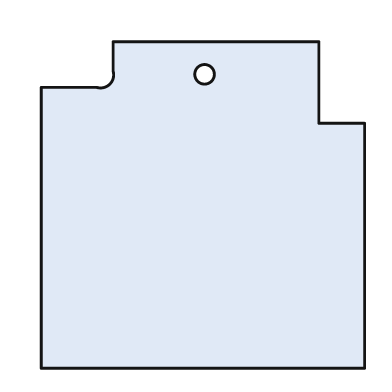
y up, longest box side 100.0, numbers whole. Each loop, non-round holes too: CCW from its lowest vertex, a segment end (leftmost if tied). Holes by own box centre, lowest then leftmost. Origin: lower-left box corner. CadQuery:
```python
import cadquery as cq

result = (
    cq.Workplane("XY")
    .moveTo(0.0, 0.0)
    .lineTo(99.0, 0.0)
    .lineTo(99.0, 75.0)
    .lineTo(85.0, 75.0)
    .lineTo(85.0, 100.0)
    .lineTo(22.0, 100.0)
    .lineTo(22.0, 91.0)
    .threePointArc((21.0, 87.0), (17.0, 86.0))
    .lineTo(0.0, 86.0)
    .close()
    .moveTo(50.0, 90.0)
    .circle(3.0)
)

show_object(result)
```